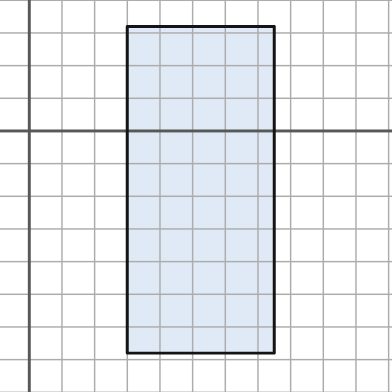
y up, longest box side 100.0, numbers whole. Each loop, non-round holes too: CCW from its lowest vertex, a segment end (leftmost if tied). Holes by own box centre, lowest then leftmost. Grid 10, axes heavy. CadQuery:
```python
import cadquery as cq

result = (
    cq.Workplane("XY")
    .moveTo(30.0, -68.0)
    .lineTo(75.0, -68.0)
    .lineTo(75.0, 32.0)
    .lineTo(30.0, 32.0)
    .close()
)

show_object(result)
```